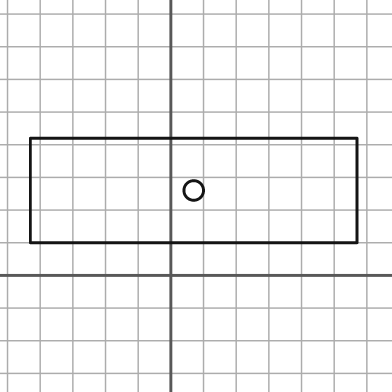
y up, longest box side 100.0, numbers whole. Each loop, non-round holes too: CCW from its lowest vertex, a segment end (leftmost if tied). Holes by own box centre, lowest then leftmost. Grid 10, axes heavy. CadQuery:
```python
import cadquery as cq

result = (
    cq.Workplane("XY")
    .moveTo(-43.0, 10.0)
    .lineTo(57.0, 10.0)
    .lineTo(57.0, 42.0)
    .lineTo(-43.0, 42.0)
    .close()
    .moveTo(7.0, 26.0)
    .circle(3.0)
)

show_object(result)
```